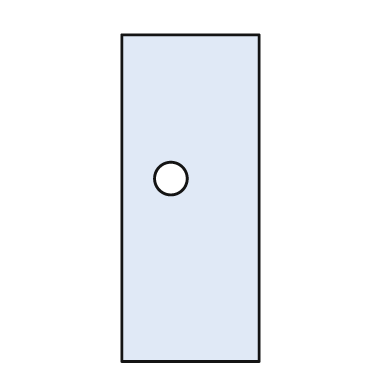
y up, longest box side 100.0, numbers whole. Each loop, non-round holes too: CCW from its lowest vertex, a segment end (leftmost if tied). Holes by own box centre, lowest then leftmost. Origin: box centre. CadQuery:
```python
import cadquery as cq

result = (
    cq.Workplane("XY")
    .moveTo(-21.0, -50.0)
    .lineTo(21.0, -50.0)
    .lineTo(21.0, 50.0)
    .lineTo(-21.0, 50.0)
    .close()
    .moveTo(-6.0, 6.0)
    .circle(5.0)
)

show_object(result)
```